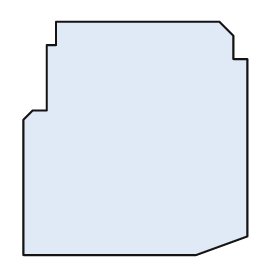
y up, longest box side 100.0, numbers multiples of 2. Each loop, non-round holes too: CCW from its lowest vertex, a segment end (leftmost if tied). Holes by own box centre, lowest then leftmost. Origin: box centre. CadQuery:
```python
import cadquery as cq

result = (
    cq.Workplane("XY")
    .moveTo(-48.0, -50.0)
    .lineTo(26.0, -50.0)
    .lineTo(48.0, -42.0)
    .lineTo(48.0, 34.0)
    .lineTo(42.0, 34.0)
    .lineTo(42.0, 44.0)
    .lineTo(36.0, 50.0)
    .lineTo(-34.0, 50.0)
    .lineTo(-34.0, 40.0)
    .lineTo(-38.0, 40.0)
    .lineTo(-38.0, 12.0)
    .lineTo(-44.0, 12.0)
    .lineTo(-48.0, 8.0)
    .close()
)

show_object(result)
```